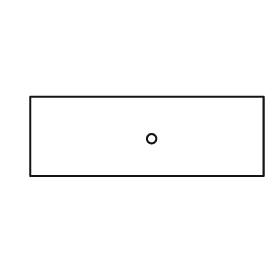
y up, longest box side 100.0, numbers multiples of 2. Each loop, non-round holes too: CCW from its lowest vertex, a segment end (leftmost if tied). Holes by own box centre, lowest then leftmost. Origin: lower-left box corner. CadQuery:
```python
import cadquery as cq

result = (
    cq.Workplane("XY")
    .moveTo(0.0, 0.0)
    .lineTo(100.0, 0.0)
    .lineTo(100.0, 34.0)
    .lineTo(0.0, 34.0)
    .close()
    .moveTo(52.0, 16.0)
    .circle(2.0)
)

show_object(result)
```